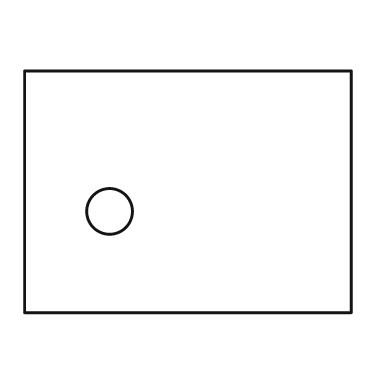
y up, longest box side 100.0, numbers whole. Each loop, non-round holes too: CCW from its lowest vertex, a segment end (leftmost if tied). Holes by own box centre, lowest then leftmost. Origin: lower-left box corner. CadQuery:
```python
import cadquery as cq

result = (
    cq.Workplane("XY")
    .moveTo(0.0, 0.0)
    .lineTo(100.0, 0.0)
    .lineTo(100.0, 74.0)
    .lineTo(0.0, 74.0)
    .close()
    .moveTo(26.0, 31.0)
    .circle(7.0)
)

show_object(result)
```